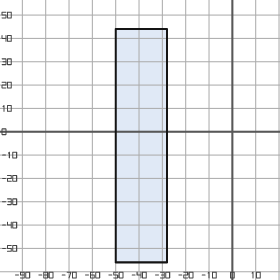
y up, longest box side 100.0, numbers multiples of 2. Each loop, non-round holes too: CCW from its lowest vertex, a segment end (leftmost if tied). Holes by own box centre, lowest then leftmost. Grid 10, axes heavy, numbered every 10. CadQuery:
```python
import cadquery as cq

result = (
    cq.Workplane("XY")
    .moveTo(-50.0, -56.0)
    .lineTo(-28.0, -56.0)
    .lineTo(-28.0, 44.0)
    .lineTo(-50.0, 44.0)
    .close()
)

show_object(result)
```